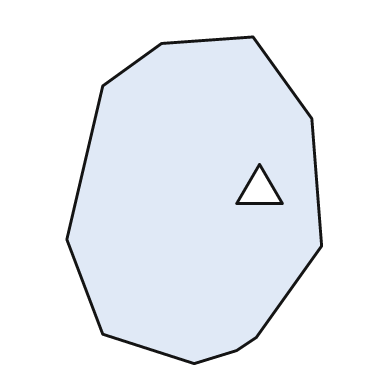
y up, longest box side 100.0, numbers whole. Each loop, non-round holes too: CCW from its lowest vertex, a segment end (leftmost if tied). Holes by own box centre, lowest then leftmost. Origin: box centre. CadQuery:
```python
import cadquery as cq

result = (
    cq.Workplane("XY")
    .moveTo(0.0, -50.0)
    .lineTo(13.0, -46.0)
    .lineTo(19.0, -42.0)
    .lineTo(39.0, -14.0)
    .lineTo(36.0, 25.0)
    .lineTo(18.0, 50.0)
    .lineTo(-10.0, 48.0)
    .lineTo(-28.0, 35.0)
    .lineTo(-39.0, -12.0)
    .lineTo(-28.0, -41.0)
    .close()
    .moveTo(13.0, -1.0)
    .lineTo(27.0, -1.0)
    .lineTo(20.0, 11.0)
    .close()
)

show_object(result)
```